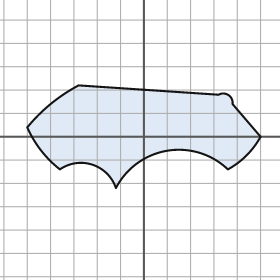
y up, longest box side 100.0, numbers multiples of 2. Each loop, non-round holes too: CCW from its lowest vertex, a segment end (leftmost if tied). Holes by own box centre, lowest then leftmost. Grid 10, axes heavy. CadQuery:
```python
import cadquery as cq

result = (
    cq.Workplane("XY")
    .moveTo(-12.0, -22.0)
    .threePointArc((10.0, -6.0), (36.0, -14.0))
    .threePointArc((44.0, -8.0), (50.0, 0.0))
    .lineTo(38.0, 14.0)
    .threePointArc((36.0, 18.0), (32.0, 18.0))
    .lineTo(-28.0, 22.0)
    .threePointArc((-40.0, 14.0), (-50.0, 4.0))
    .threePointArc((-44.0, -6.0), (-36.0, -14.0))
    .threePointArc((-22.0, -12.0), (-12.0, -22.0))
    .close()
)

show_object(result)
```